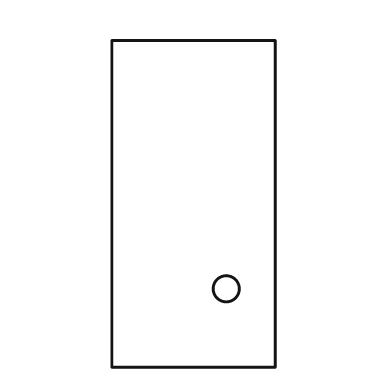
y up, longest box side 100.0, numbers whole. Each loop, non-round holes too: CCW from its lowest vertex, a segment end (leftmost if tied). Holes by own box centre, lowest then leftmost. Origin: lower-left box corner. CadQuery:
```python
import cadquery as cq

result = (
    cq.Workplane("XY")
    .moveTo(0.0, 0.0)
    .lineTo(50.0, 0.0)
    .lineTo(50.0, 100.0)
    .lineTo(0.0, 100.0)
    .close()
    .moveTo(35.0, 24.0)
    .circle(4.0)
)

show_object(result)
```